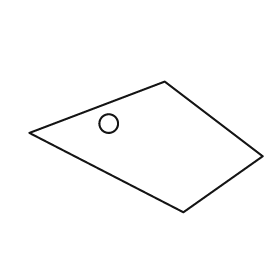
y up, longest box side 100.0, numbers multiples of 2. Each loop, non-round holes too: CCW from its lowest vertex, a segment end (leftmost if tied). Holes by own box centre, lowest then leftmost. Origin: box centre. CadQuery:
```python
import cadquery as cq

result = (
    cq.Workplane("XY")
    .moveTo(16.0, -28.0)
    .lineTo(50.0, -4.0)
    .lineTo(8.0, 28.0)
    .lineTo(-50.0, 6.0)
    .close()
    .moveTo(-16.0, 10.0)
    .circle(4.0)
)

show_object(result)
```